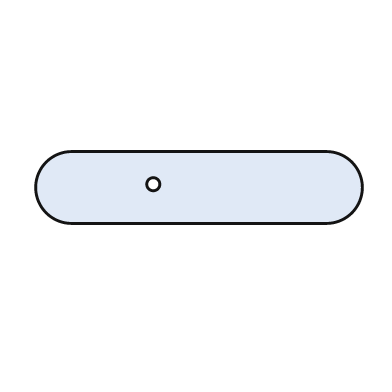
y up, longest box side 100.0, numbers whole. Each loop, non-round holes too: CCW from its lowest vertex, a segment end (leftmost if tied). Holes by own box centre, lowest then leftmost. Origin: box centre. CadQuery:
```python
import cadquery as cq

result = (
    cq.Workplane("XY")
    .moveTo(-39.0, -11.0)
    .lineTo(39.0, -11.0)
    .threePointArc((50.0, 0.0), (39.0, 11.0))
    .lineTo(-39.0, 11.0)
    .threePointArc((-50.0, 0.0), (-39.0, -11.0))
    .close()
    .moveTo(-14.0, 1.0)
    .circle(2.0)
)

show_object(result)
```